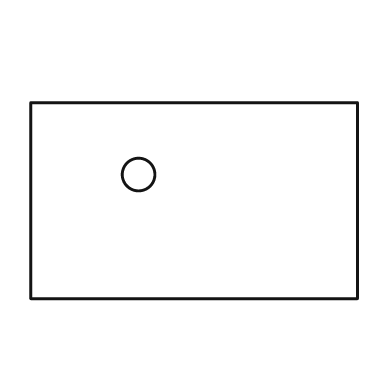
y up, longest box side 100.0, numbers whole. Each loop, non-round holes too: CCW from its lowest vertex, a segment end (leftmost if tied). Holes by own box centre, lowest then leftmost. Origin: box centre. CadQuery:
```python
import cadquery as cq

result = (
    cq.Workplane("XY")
    .moveTo(-50.0, -30.0)
    .lineTo(50.0, -30.0)
    .lineTo(50.0, 30.0)
    .lineTo(-50.0, 30.0)
    .close()
    .moveTo(-17.0, 8.0)
    .circle(5.0)
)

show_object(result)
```